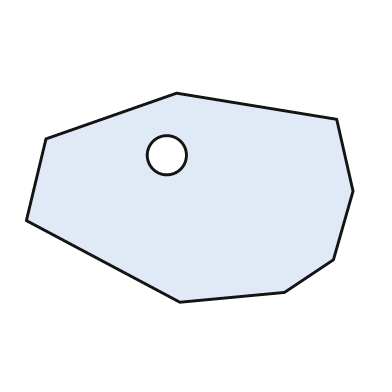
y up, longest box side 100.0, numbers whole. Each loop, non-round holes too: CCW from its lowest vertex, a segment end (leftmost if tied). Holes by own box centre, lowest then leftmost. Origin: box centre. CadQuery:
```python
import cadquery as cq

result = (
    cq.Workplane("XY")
    .moveTo(-3.0, -32.0)
    .lineTo(29.0, -29.0)
    .lineTo(44.0, -19.0)
    .lineTo(50.0, 2.0)
    .lineTo(45.0, 24.0)
    .lineTo(-4.0, 32.0)
    .lineTo(-44.0, 18.0)
    .lineTo(-50.0, -7.0)
    .close()
    .moveTo(-7.0, 13.0)
    .circle(6.0)
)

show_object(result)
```